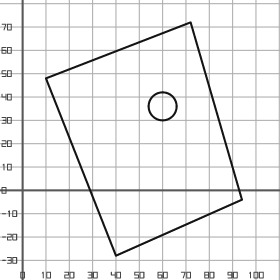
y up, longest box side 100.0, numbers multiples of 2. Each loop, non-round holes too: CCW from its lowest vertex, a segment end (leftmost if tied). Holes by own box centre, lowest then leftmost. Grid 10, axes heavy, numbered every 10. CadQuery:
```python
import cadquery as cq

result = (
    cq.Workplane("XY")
    .moveTo(40.0, -28.0)
    .lineTo(94.0, -4.0)
    .lineTo(72.0, 72.0)
    .lineTo(10.0, 48.0)
    .close()
    .moveTo(60.0, 36.0)
    .circle(6.0)
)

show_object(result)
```